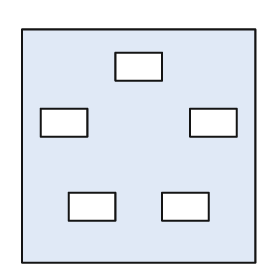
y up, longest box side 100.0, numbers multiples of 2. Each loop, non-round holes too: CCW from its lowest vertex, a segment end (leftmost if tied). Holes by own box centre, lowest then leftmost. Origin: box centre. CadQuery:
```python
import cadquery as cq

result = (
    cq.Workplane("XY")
    .moveTo(-50.0, -50.0)
    .lineTo(50.0, -50.0)
    .lineTo(50.0, 50.0)
    .lineTo(-50.0, 50.0)
    .close()
    .moveTo(-30.0, -32.0)
    .lineTo(-10.0, -32.0)
    .lineTo(-10.0, -20.0)
    .lineTo(-30.0, -20.0)
    .close()
    .moveTo(10.0, -32.0)
    .lineTo(30.0, -32.0)
    .lineTo(30.0, -20.0)
    .lineTo(10.0, -20.0)
    .close()
    .moveTo(-42.0, 4.0)
    .lineTo(-22.0, 4.0)
    .lineTo(-22.0, 16.0)
    .lineTo(-42.0, 16.0)
    .close()
    .moveTo(22.0, 4.0)
    .lineTo(42.0, 4.0)
    .lineTo(42.0, 16.0)
    .lineTo(22.0, 16.0)
    .close()
    .moveTo(-10.0, 28.0)
    .lineTo(10.0, 28.0)
    .lineTo(10.0, 40.0)
    .lineTo(-10.0, 40.0)
    .close()
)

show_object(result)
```